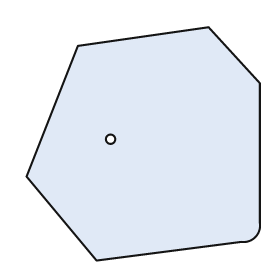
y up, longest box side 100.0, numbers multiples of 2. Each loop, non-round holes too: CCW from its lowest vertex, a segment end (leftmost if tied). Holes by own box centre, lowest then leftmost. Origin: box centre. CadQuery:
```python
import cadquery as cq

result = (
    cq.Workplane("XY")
    .moveTo(-20.0, -50.0)
    .lineTo(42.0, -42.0)
    .threePointArc((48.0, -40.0), (50.0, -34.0))
    .lineTo(50.0, 26.0)
    .lineTo(28.0, 50.0)
    .lineTo(-28.0, 42.0)
    .lineTo(-50.0, -14.0)
    .close()
    .moveTo(-14.0, 2.0)
    .circle(2.0)
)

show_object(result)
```